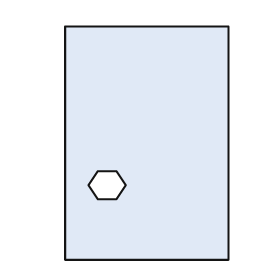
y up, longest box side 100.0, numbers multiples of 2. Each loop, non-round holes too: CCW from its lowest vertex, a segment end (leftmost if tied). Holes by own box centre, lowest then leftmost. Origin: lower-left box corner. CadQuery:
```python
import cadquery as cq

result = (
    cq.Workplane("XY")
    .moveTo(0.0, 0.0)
    .lineTo(70.0, 0.0)
    .lineTo(70.0, 100.0)
    .lineTo(0.0, 100.0)
    .close()
    .moveTo(14.0, 26.0)
    .lineTo(22.0, 26.0)
    .lineTo(26.0, 32.0)
    .lineTo(22.0, 38.0)
    .lineTo(14.0, 38.0)
    .lineTo(10.0, 32.0)
    .close()
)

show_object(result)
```